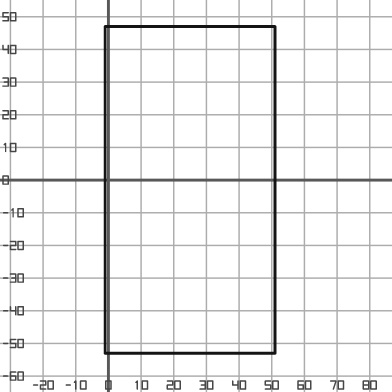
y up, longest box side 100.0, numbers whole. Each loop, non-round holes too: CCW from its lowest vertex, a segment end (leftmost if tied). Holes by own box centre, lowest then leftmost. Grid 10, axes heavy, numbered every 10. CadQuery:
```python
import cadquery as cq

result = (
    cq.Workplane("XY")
    .moveTo(-1.0, -53.0)
    .lineTo(51.0, -53.0)
    .lineTo(51.0, 47.0)
    .lineTo(-1.0, 47.0)
    .close()
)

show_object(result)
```